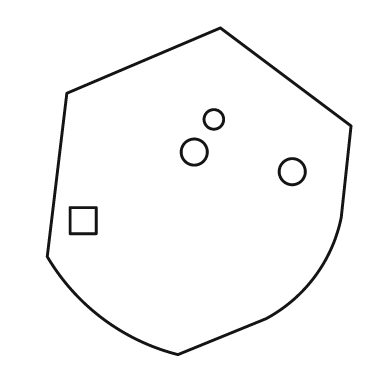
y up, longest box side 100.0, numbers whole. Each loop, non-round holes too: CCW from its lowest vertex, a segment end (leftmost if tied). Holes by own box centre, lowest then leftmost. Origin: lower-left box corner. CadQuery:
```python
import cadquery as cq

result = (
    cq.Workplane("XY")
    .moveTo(40.0, 0.0)
    .lineTo(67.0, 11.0)
    .threePointArc((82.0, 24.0), (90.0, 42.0))
    .lineTo(93.0, 70.0)
    .lineTo(53.0, 100.0)
    .lineTo(6.0, 80.0)
    .lineTo(0.0, 30.0)
    .threePointArc((17.0, 11.0), (40.0, 0.0))
    .close()
    .moveTo(7.0, 37.0)
    .lineTo(15.0, 37.0)
    .lineTo(15.0, 45.0)
    .lineTo(7.0, 45.0)
    .close()
    .moveTo(75.0, 56.0)
    .circle(4.0)
    .moveTo(45.0, 62.0)
    .circle(4.0)
    .moveTo(51.0, 72.0)
    .circle(3.0)
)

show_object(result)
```